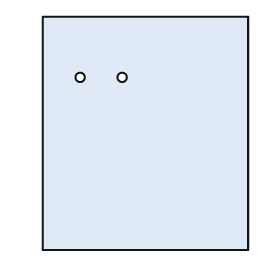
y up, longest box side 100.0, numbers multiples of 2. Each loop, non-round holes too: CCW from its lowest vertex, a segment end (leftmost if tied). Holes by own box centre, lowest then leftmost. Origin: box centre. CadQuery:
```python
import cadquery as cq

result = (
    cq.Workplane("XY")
    .moveTo(-44.0, -50.0)
    .lineTo(44.0, -50.0)
    .lineTo(44.0, 50.0)
    .lineTo(-44.0, 50.0)
    .close()
    .moveTo(-28.0, 24.0)
    .circle(2.0)
    .moveTo(-10.0, 24.0)
    .circle(2.0)
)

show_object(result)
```